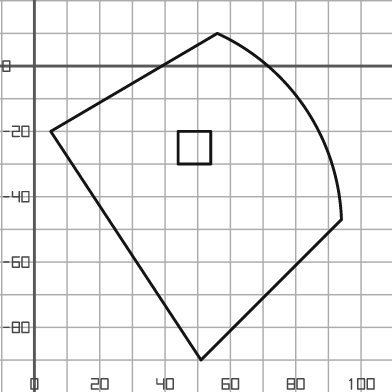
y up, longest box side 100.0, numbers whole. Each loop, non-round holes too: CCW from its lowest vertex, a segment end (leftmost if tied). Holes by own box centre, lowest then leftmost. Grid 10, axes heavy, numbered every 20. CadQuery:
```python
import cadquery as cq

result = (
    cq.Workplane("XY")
    .moveTo(51.0, -90.0)
    .lineTo(94.0, -47.0)
    .threePointArc((83.0, -13.0), (56.0, 10.0))
    .lineTo(5.0, -20.0)
    .close()
    .moveTo(44.0, -30.0)
    .lineTo(54.0, -30.0)
    .lineTo(54.0, -20.0)
    .lineTo(44.0, -20.0)
    .close()
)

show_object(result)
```